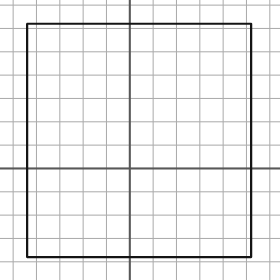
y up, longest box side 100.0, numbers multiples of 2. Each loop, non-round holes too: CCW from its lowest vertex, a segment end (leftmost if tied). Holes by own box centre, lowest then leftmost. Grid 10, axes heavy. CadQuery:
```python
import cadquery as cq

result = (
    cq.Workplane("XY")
    .moveTo(-44.0, -38.0)
    .lineTo(52.0, -38.0)
    .lineTo(52.0, 62.0)
    .lineTo(-44.0, 62.0)
    .close()
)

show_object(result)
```